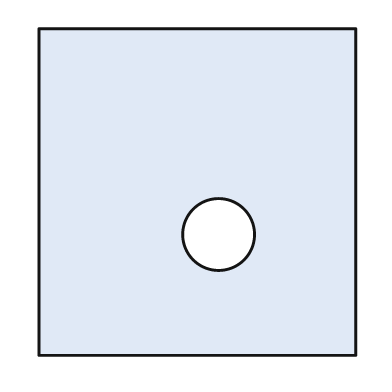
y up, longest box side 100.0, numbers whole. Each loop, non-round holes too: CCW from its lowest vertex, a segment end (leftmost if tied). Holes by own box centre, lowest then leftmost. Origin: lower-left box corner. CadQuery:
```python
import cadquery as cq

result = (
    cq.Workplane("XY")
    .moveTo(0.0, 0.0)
    .lineTo(97.0, 0.0)
    .lineTo(97.0, 100.0)
    .lineTo(0.0, 100.0)
    .close()
    .moveTo(55.0, 37.0)
    .circle(11.0)
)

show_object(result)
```